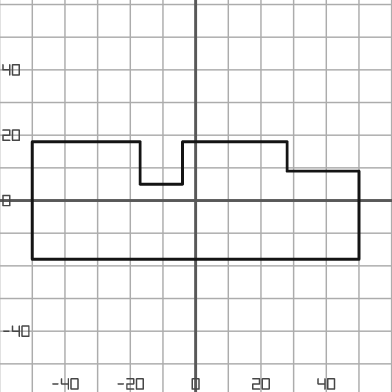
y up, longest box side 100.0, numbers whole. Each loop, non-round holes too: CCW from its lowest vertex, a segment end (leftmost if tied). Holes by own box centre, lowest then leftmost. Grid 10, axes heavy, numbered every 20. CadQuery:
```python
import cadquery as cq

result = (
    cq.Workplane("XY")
    .moveTo(-50.0, -18.0)
    .lineTo(50.0, -18.0)
    .lineTo(50.0, 9.0)
    .lineTo(28.0, 9.0)
    .lineTo(28.0, 18.0)
    .lineTo(-4.0, 18.0)
    .lineTo(-4.0, 5.0)
    .lineTo(-17.0, 5.0)
    .lineTo(-17.0, 18.0)
    .lineTo(-50.0, 18.0)
    .close()
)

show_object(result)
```